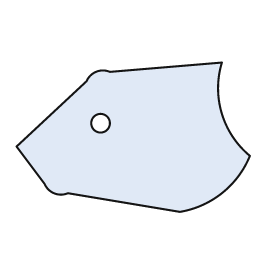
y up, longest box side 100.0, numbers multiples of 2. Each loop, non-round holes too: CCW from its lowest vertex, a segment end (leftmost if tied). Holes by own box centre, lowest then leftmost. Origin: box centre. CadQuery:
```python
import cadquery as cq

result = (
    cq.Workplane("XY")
    .moveTo(20.0, -32.0)
    .threePointArc((38.0, -24.0), (50.0, -8.0))
    .threePointArc((38.0, 10.0), (38.0, 32.0))
    .lineTo(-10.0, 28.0)
    .threePointArc((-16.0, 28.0), (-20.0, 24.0))
    .lineTo(-50.0, -4.0)
    .lineTo(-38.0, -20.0)
    .threePointArc((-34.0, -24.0), (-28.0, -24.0))
    .close()
    .moveTo(-14.0, 6.0)
    .circle(4.0)
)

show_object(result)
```